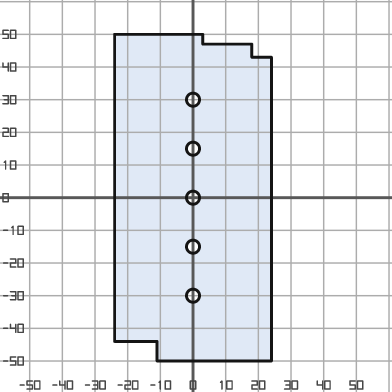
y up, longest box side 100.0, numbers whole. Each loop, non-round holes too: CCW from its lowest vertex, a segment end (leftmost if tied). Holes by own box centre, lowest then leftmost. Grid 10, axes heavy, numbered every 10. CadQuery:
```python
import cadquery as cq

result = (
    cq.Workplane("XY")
    .moveTo(-11.0, -50.0)
    .lineTo(24.0, -50.0)
    .lineTo(24.0, 43.0)
    .lineTo(18.0, 43.0)
    .lineTo(18.0, 47.0)
    .lineTo(3.0, 47.0)
    .lineTo(3.0, 50.0)
    .lineTo(-24.0, 50.0)
    .lineTo(-24.0, -44.0)
    .lineTo(-11.0, -44.0)
    .close()
    .moveTo(0.0, -30.0)
    .circle(2.0)
    .moveTo(0.0, -15.0)
    .circle(2.0)
    .moveTo(0.0, 0.0)
    .circle(2.0)
    .moveTo(0.0, 15.0)
    .circle(2.0)
    .moveTo(0.0, 30.0)
    .circle(2.0)
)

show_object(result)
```